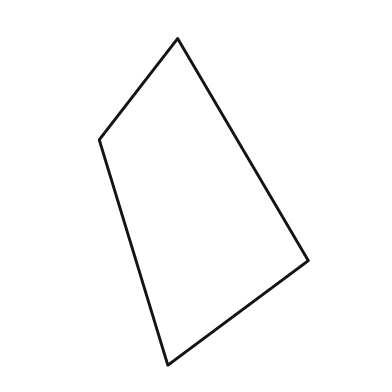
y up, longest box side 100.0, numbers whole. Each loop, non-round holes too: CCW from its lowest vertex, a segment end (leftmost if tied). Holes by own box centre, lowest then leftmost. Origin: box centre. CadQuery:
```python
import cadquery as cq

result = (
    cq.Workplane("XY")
    .moveTo(-11.0, -50.0)
    .lineTo(32.0, -18.0)
    .lineTo(-8.0, 50.0)
    .lineTo(-32.0, 19.0)
    .close()
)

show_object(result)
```